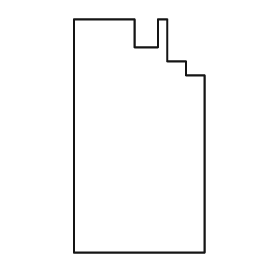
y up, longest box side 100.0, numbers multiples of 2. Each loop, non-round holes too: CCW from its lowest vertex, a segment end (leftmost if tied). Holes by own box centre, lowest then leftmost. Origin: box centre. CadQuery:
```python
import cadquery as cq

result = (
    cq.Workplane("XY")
    .moveTo(-28.0, -50.0)
    .lineTo(28.0, -50.0)
    .lineTo(28.0, 26.0)
    .lineTo(20.0, 26.0)
    .lineTo(20.0, 32.0)
    .lineTo(12.0, 32.0)
    .lineTo(12.0, 50.0)
    .lineTo(8.0, 50.0)
    .lineTo(8.0, 38.0)
    .lineTo(-2.0, 38.0)
    .lineTo(-2.0, 50.0)
    .lineTo(-28.0, 50.0)
    .close()
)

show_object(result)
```